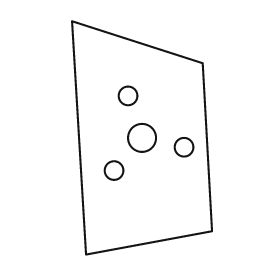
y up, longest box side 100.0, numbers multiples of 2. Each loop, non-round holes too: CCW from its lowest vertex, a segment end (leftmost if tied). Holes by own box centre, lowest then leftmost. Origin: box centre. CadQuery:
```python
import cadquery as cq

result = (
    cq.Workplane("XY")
    .moveTo(-24.0, -50.0)
    .lineTo(30.0, -40.0)
    .lineTo(26.0, 32.0)
    .lineTo(-30.0, 50.0)
    .close()
    .moveTo(-12.0, -14.0)
    .circle(4.0)
    .moveTo(18.0, -4.0)
    .circle(4.0)
    .moveTo(0.0, 0.0)
    .circle(6.0)
    .moveTo(-6.0, 18.0)
    .circle(4.0)
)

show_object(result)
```